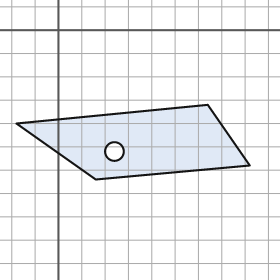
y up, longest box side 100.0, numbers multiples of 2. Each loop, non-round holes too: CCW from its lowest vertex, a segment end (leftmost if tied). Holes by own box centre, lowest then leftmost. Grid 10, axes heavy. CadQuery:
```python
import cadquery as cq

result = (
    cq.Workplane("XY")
    .moveTo(16.0, -64.0)
    .lineTo(82.0, -58.0)
    .lineTo(64.0, -32.0)
    .lineTo(-18.0, -40.0)
    .close()
    .moveTo(24.0, -52.0)
    .circle(4.0)
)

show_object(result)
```